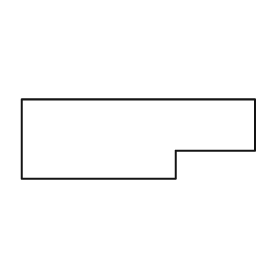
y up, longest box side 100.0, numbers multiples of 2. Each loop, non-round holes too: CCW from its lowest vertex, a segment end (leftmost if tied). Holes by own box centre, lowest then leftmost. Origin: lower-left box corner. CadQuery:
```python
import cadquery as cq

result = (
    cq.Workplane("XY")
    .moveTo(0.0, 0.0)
    .lineTo(66.0, 0.0)
    .lineTo(66.0, 12.0)
    .lineTo(100.0, 12.0)
    .lineTo(100.0, 34.0)
    .lineTo(0.0, 34.0)
    .close()
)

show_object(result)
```